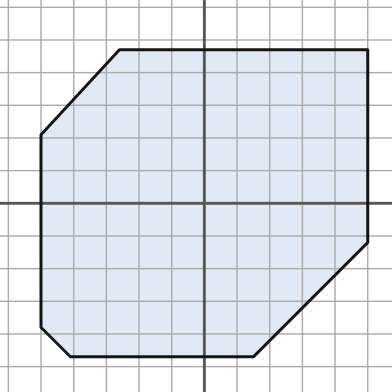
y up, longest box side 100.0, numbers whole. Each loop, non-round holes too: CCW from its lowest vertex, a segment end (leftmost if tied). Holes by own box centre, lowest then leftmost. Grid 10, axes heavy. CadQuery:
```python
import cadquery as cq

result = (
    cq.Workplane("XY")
    .moveTo(-41.0, -47.0)
    .lineTo(15.0, -47.0)
    .lineTo(50.0, -12.0)
    .lineTo(50.0, 47.0)
    .lineTo(-26.0, 47.0)
    .lineTo(-50.0, 21.0)
    .lineTo(-50.0, -38.0)
    .close()
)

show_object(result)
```